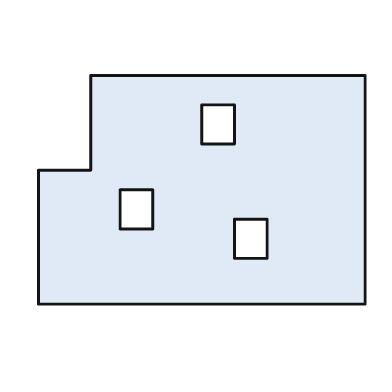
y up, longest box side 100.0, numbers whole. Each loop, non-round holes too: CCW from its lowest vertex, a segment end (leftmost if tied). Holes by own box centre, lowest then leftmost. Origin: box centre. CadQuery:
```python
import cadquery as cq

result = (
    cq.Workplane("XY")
    .moveTo(-50.0, -35.0)
    .lineTo(50.0, -35.0)
    .lineTo(50.0, 35.0)
    .lineTo(-34.0, 35.0)
    .lineTo(-34.0, 6.0)
    .lineTo(-50.0, 6.0)
    .close()
    .moveTo(10.0, -21.0)
    .lineTo(20.0, -21.0)
    .lineTo(20.0, -9.0)
    .lineTo(10.0, -9.0)
    .close()
    .moveTo(-25.0, -12.0)
    .lineTo(-15.0, -12.0)
    .lineTo(-15.0, 0.0)
    .lineTo(-25.0, 0.0)
    .close()
    .moveTo(0.0, 14.0)
    .lineTo(10.0, 14.0)
    .lineTo(10.0, 26.0)
    .lineTo(0.0, 26.0)
    .close()
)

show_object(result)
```